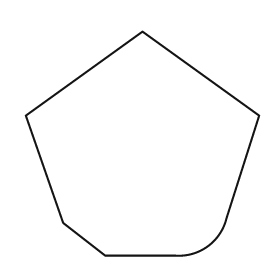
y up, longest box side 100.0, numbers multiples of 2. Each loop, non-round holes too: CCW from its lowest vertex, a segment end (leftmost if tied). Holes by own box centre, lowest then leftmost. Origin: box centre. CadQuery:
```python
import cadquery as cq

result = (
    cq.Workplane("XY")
    .moveTo(-16.0, -48.0)
    .lineTo(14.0, -48.0)
    .threePointArc((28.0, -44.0), (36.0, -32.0))
    .lineTo(50.0, 12.0)
    .lineTo(0.0, 48.0)
    .lineTo(-50.0, 12.0)
    .lineTo(-34.0, -34.0)
    .close()
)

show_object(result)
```